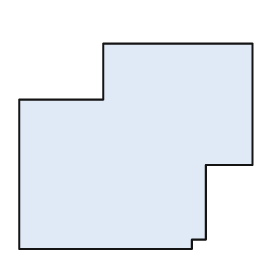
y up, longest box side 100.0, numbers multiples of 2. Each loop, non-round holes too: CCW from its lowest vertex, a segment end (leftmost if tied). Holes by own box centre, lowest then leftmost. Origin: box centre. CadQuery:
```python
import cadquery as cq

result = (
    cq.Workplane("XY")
    .moveTo(-50.0, -44.0)
    .lineTo(24.0, -44.0)
    .lineTo(24.0, -40.0)
    .lineTo(30.0, -40.0)
    .lineTo(30.0, -8.0)
    .lineTo(50.0, -8.0)
    .lineTo(50.0, 44.0)
    .lineTo(-14.0, 44.0)
    .lineTo(-14.0, 20.0)
    .lineTo(-50.0, 20.0)
    .close()
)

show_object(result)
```